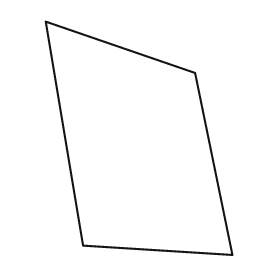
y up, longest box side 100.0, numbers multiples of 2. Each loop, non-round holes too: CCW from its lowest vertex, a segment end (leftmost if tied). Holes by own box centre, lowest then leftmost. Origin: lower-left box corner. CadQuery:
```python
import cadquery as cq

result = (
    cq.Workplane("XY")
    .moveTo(80.0, 0.0)
    .lineTo(64.0, 78.0)
    .lineTo(0.0, 100.0)
    .lineTo(16.0, 4.0)
    .close()
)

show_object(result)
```